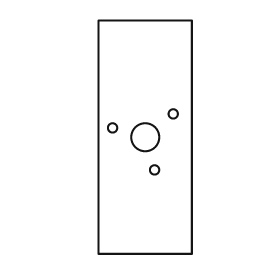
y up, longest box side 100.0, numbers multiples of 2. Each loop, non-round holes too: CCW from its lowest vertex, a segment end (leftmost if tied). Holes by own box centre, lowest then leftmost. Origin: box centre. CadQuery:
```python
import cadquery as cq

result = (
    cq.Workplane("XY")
    .moveTo(-20.0, -50.0)
    .lineTo(20.0, -50.0)
    .lineTo(20.0, 50.0)
    .lineTo(-20.0, 50.0)
    .close()
    .moveTo(4.0, -14.0)
    .circle(2.0)
    .moveTo(0.0, 0.0)
    .circle(6.0)
    .moveTo(-14.0, 4.0)
    .circle(2.0)
    .moveTo(12.0, 10.0)
    .circle(2.0)
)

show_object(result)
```